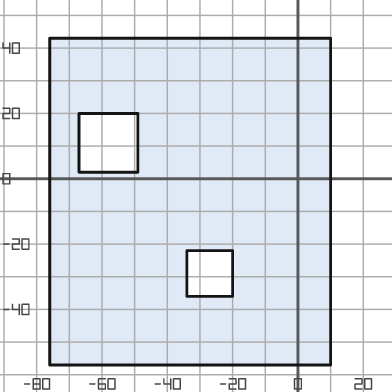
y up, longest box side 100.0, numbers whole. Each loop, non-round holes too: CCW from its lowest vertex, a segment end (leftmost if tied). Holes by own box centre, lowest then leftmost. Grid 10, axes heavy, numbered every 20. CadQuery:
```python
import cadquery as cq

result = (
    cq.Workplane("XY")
    .moveTo(-76.0, -57.0)
    .lineTo(10.0, -57.0)
    .lineTo(10.0, 43.0)
    .lineTo(-76.0, 43.0)
    .close()
    .moveTo(-34.0, -36.0)
    .lineTo(-20.0, -36.0)
    .lineTo(-20.0, -22.0)
    .lineTo(-34.0, -22.0)
    .close()
    .moveTo(-67.0, 2.0)
    .lineTo(-49.0, 2.0)
    .lineTo(-49.0, 20.0)
    .lineTo(-67.0, 20.0)
    .close()
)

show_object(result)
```